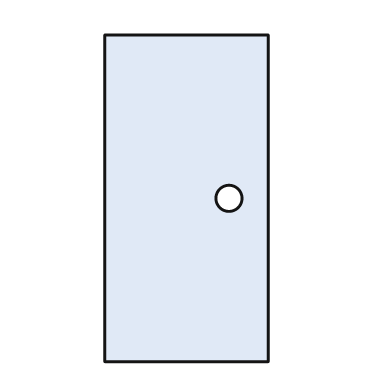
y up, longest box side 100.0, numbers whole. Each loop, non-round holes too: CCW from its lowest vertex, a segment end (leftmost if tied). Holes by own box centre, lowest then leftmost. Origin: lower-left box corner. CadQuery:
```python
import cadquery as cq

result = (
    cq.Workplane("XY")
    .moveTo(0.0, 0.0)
    .lineTo(50.0, 0.0)
    .lineTo(50.0, 100.0)
    .lineTo(0.0, 100.0)
    .close()
    .moveTo(38.0, 50.0)
    .circle(4.0)
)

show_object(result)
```